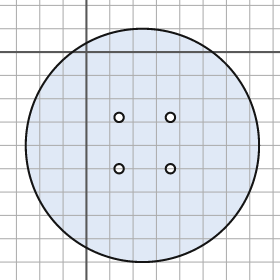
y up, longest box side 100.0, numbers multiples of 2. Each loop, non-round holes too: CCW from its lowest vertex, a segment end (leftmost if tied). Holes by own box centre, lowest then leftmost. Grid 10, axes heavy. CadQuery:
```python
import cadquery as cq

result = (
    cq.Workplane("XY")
    .moveTo(24.0, -40.0)
    .circle(50.0)
    .moveTo(14.0, -50.0)
    .circle(2.0)
    .moveTo(36.0, -50.0)
    .circle(2.0)
    .moveTo(14.0, -28.0)
    .circle(2.0)
    .moveTo(36.0, -28.0)
    .circle(2.0)
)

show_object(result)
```